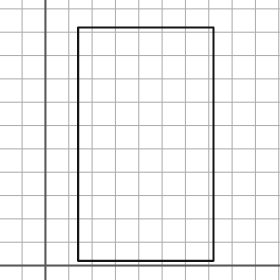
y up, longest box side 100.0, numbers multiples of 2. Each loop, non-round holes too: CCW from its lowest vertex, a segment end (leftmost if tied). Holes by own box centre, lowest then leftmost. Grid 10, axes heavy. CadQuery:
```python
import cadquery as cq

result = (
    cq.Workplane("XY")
    .moveTo(14.0, 2.0)
    .lineTo(72.0, 2.0)
    .lineTo(72.0, 102.0)
    .lineTo(14.0, 102.0)
    .close()
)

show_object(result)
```